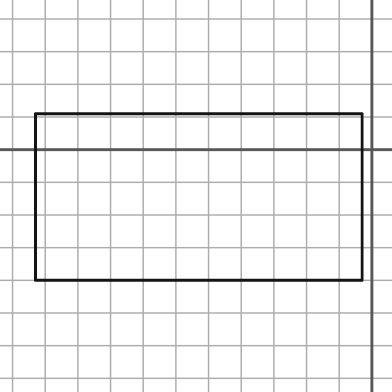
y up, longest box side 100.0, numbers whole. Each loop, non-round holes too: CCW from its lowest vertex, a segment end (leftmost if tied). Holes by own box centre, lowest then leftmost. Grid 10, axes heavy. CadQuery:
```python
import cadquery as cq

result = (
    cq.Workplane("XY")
    .moveTo(-103.0, -40.0)
    .lineTo(-3.0, -40.0)
    .lineTo(-3.0, 11.0)
    .lineTo(-103.0, 11.0)
    .close()
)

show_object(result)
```